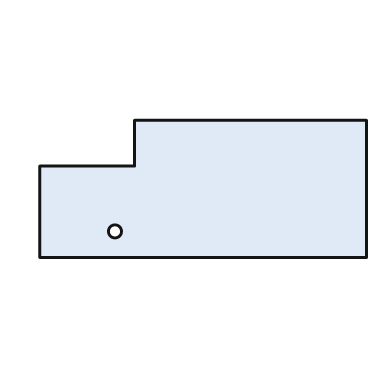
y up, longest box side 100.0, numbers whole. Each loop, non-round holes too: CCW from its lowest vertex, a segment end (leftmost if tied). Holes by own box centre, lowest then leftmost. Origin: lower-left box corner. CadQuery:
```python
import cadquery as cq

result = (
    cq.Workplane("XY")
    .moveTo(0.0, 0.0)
    .lineTo(100.0, 0.0)
    .lineTo(100.0, 42.0)
    .lineTo(29.0, 42.0)
    .lineTo(29.0, 28.0)
    .lineTo(0.0, 28.0)
    .close()
    .moveTo(23.0, 8.0)
    .circle(2.0)
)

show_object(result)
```